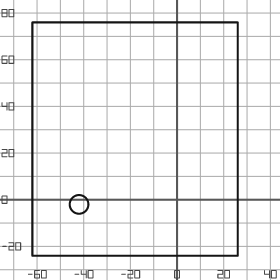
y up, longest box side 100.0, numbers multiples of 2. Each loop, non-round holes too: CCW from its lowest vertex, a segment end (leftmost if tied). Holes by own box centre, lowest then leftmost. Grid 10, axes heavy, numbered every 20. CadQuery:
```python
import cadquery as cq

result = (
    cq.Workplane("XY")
    .moveTo(-62.0, -24.0)
    .lineTo(26.0, -24.0)
    .lineTo(26.0, 76.0)
    .lineTo(-62.0, 76.0)
    .close()
    .moveTo(-42.0, -2.0)
    .circle(4.0)
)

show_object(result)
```